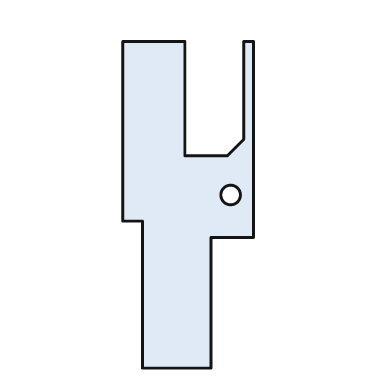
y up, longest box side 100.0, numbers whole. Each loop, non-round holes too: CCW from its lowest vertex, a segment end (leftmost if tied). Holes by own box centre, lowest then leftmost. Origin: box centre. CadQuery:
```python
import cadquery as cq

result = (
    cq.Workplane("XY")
    .moveTo(-14.0, -50.0)
    .lineTo(7.0, -50.0)
    .lineTo(7.0, -10.0)
    .lineTo(20.0, -10.0)
    .lineTo(20.0, 50.0)
    .lineTo(17.0, 50.0)
    .lineTo(17.0, 20.0)
    .lineTo(12.0, 15.0)
    .lineTo(-1.0, 15.0)
    .lineTo(-1.0, 50.0)
    .lineTo(-20.0, 50.0)
    .lineTo(-20.0, -5.0)
    .lineTo(-14.0, -5.0)
    .close()
    .moveTo(13.0, 3.0)
    .circle(3.0)
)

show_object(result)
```